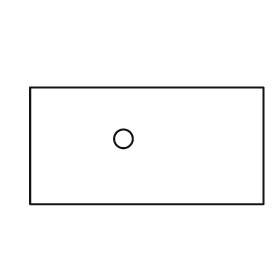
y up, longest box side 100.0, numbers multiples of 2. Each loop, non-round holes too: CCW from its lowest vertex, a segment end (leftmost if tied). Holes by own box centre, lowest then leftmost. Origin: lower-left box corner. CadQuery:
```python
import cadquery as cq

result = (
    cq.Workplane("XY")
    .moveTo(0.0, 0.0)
    .lineTo(100.0, 0.0)
    .lineTo(100.0, 50.0)
    .lineTo(0.0, 50.0)
    .close()
    .moveTo(40.0, 28.0)
    .circle(4.0)
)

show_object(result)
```